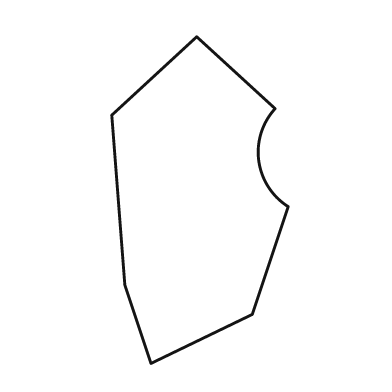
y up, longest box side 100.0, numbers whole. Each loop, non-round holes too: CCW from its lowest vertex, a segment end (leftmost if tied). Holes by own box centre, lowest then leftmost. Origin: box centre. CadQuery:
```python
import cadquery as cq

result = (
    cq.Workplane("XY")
    .moveTo(-15.0, -50.0)
    .lineTo(16.0, -35.0)
    .lineTo(27.0, -2.0)
    .threePointArc((18.0, 12.0), (23.0, 28.0))
    .lineTo(-1.0, 50.0)
    .lineTo(-27.0, 26.0)
    .lineTo(-23.0, -26.0)
    .close()
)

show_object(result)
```